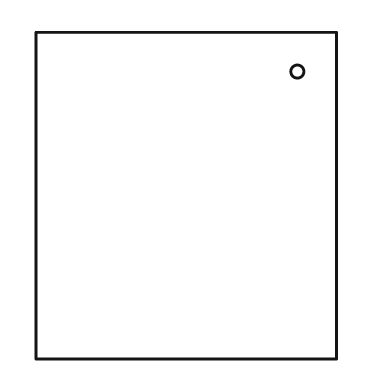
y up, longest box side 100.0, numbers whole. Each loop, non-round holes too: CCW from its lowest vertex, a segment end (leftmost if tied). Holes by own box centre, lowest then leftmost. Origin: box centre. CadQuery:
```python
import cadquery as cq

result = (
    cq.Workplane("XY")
    .moveTo(-46.0, -50.0)
    .lineTo(46.0, -50.0)
    .lineTo(46.0, 50.0)
    .lineTo(-46.0, 50.0)
    .close()
    .moveTo(34.0, 38.0)
    .circle(2.0)
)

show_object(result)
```